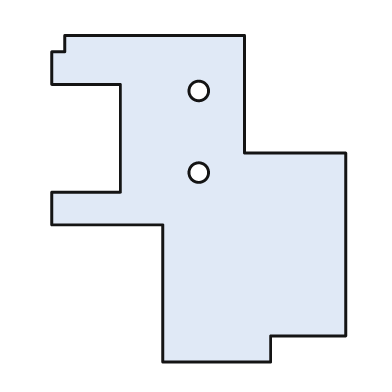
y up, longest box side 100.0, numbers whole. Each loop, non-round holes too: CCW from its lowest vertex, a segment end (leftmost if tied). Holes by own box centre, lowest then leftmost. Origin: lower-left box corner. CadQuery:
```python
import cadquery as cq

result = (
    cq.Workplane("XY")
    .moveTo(34.0, 0.0)
    .lineTo(67.0, 0.0)
    .lineTo(67.0, 8.0)
    .lineTo(90.0, 8.0)
    .lineTo(90.0, 64.0)
    .lineTo(59.0, 64.0)
    .lineTo(59.0, 100.0)
    .lineTo(4.0, 100.0)
    .lineTo(4.0, 95.0)
    .lineTo(0.0, 95.0)
    .lineTo(0.0, 85.0)
    .lineTo(21.0, 85.0)
    .lineTo(21.0, 52.0)
    .lineTo(0.0, 52.0)
    .lineTo(0.0, 42.0)
    .lineTo(34.0, 42.0)
    .close()
    .moveTo(45.0, 58.0)
    .circle(3.0)
    .moveTo(45.0, 83.0)
    .circle(3.0)
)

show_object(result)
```